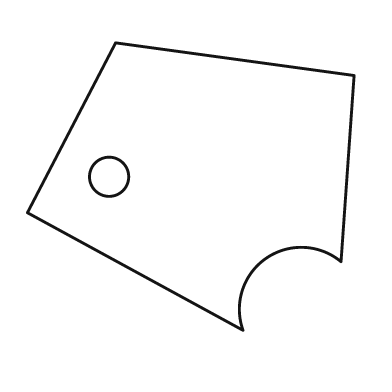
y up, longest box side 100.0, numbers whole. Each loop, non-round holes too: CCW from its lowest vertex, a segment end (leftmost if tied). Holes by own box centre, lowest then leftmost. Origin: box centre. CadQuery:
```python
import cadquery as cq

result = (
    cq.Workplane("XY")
    .moveTo(16.0, -44.0)
    .threePointArc((23.0, -22.0), (46.0, -23.0))
    .lineTo(50.0, 34.0)
    .lineTo(-23.0, 44.0)
    .lineTo(-50.0, -8.0)
    .close()
    .moveTo(-25.0, 3.0)
    .circle(6.0)
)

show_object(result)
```